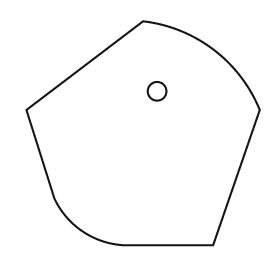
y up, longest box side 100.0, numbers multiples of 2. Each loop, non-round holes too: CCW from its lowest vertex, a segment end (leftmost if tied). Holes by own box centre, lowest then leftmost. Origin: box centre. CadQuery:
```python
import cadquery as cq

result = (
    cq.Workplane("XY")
    .moveTo(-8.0, -48.0)
    .lineTo(30.0, -48.0)
    .lineTo(50.0, 10.0)
    .threePointArc((30.0, 36.0), (0.0, 48.0))
    .lineTo(-50.0, 10.0)
    .lineTo(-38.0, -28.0)
    .threePointArc((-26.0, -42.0), (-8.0, -48.0))
    .close()
    .moveTo(6.0, 18.0)
    .circle(4.0)
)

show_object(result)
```